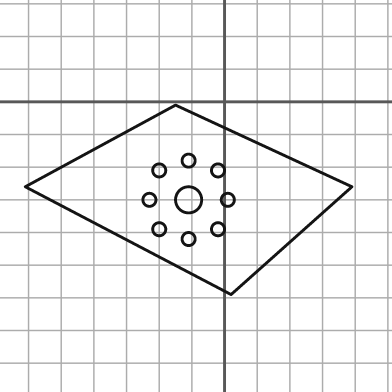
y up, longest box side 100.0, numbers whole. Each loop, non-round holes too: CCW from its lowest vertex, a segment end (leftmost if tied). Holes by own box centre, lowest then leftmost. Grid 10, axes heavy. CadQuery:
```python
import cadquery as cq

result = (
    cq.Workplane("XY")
    .moveTo(2.0, -59.0)
    .lineTo(39.0, -26.0)
    .lineTo(-15.0, -1.0)
    .lineTo(-61.0, -26.0)
    .close()
    .moveTo(-11.0, -42.0)
    .circle(2.0)
    .moveTo(-20.0, -39.0)
    .circle(2.0)
    .moveTo(-2.0, -39.0)
    .circle(2.0)
    .moveTo(-23.0, -30.0)
    .circle(2.0)
    .moveTo(-11.0, -30.0)
    .circle(4.0)
    .moveTo(1.0, -30.0)
    .circle(2.0)
    .moveTo(-20.0, -21.0)
    .circle(2.0)
    .moveTo(-2.0, -21.0)
    .circle(2.0)
    .moveTo(-11.0, -18.0)
    .circle(2.0)
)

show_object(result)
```